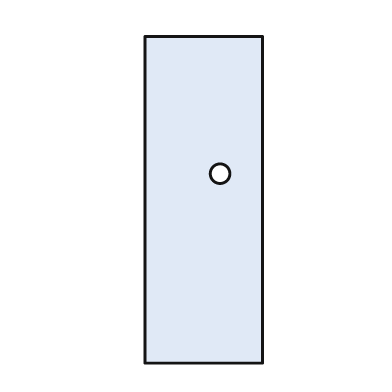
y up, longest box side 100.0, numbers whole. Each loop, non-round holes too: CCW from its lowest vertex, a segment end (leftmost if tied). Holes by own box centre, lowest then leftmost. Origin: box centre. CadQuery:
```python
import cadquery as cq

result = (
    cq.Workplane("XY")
    .moveTo(-18.0, -50.0)
    .lineTo(18.0, -50.0)
    .lineTo(18.0, 50.0)
    .lineTo(-18.0, 50.0)
    .close()
    .moveTo(5.0, 8.0)
    .circle(3.0)
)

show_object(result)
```